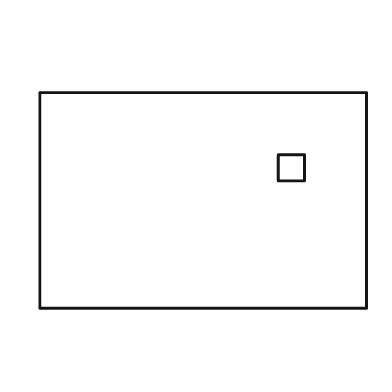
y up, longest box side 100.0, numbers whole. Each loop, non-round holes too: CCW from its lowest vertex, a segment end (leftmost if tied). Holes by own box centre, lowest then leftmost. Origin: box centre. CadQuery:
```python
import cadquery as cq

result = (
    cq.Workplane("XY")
    .moveTo(-50.0, -33.0)
    .lineTo(50.0, -33.0)
    .lineTo(50.0, 33.0)
    .lineTo(-50.0, 33.0)
    .close()
    .moveTo(23.0, 6.0)
    .lineTo(31.0, 6.0)
    .lineTo(31.0, 14.0)
    .lineTo(23.0, 14.0)
    .close()
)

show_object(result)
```